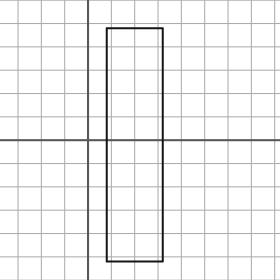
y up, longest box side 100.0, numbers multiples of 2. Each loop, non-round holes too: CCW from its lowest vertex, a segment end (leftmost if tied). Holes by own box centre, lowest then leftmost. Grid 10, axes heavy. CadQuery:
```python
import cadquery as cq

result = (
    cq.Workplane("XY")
    .moveTo(8.0, -52.0)
    .lineTo(32.0, -52.0)
    .lineTo(32.0, 48.0)
    .lineTo(8.0, 48.0)
    .close()
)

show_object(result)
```